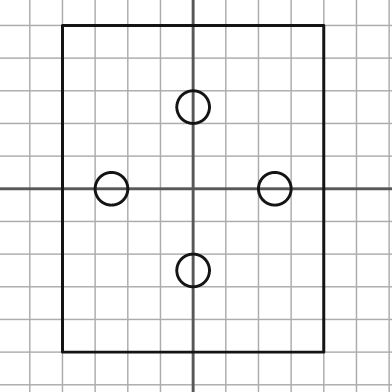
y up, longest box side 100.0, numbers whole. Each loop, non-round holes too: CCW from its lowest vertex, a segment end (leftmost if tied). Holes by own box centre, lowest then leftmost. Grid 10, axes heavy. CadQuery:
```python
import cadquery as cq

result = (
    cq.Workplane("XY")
    .moveTo(-40.0, -50.0)
    .lineTo(40.0, -50.0)
    .lineTo(40.0, 50.0)
    .lineTo(-40.0, 50.0)
    .close()
    .moveTo(0.0, -25.0)
    .circle(5.0)
    .moveTo(-25.0, 0.0)
    .circle(5.0)
    .moveTo(25.0, 0.0)
    .circle(5.0)
    .moveTo(0.0, 25.0)
    .circle(5.0)
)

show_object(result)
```